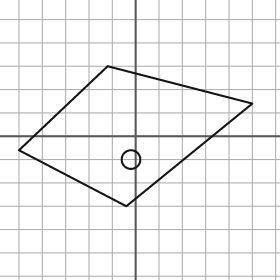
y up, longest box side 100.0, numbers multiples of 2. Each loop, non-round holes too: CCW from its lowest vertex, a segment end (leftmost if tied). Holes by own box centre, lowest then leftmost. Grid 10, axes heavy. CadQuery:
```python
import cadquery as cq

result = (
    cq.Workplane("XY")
    .moveTo(-4.0, -30.0)
    .lineTo(50.0, 14.0)
    .lineTo(-12.0, 30.0)
    .lineTo(-50.0, -6.0)
    .close()
    .moveTo(-2.0, -10.0)
    .circle(4.0)
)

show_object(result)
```